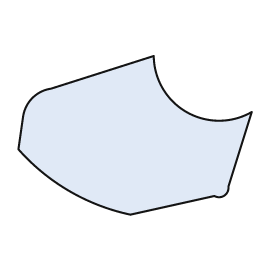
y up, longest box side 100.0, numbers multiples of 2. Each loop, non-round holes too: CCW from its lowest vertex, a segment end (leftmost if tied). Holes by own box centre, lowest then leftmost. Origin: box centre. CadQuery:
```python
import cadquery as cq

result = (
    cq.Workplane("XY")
    .moveTo(-2.0, -34.0)
    .lineTo(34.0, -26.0)
    .threePointArc((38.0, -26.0), (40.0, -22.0))
    .lineTo(50.0, 10.0)
    .threePointArc((22.0, 10.0), (8.0, 34.0))
    .lineTo(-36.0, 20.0)
    .threePointArc((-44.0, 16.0), (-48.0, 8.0))
    .lineTo(-50.0, -6.0)
    .threePointArc((-28.0, -24.0), (-2.0, -34.0))
    .close()
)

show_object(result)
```